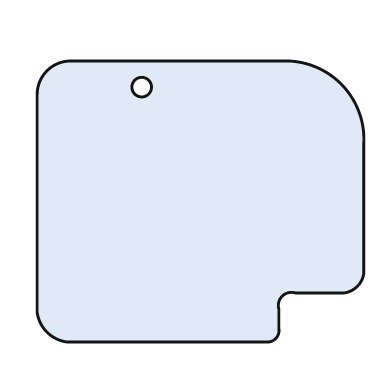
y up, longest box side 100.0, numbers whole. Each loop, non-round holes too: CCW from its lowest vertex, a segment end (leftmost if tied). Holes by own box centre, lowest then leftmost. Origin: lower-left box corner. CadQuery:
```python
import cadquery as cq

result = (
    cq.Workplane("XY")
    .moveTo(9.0, 0.0)
    .lineTo(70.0, 0.0)
    .threePointArc((73.0, 1.0), (74.0, 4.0))
    .lineTo(74.0, 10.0)
    .threePointArc((75.0, 14.0), (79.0, 15.0))
    .lineTo(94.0, 15.0)
    .threePointArc((98.0, 17.0), (100.0, 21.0))
    .lineTo(100.0, 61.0)
    .threePointArc((93.0, 79.0), (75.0, 86.0))
    .lineTo(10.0, 86.0)
    .threePointArc((3.0, 83.0), (0.0, 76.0))
    .lineTo(0.0, 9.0)
    .threePointArc((3.0, 3.0), (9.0, 0.0))
    .close()
    .moveTo(32.0, 78.0)
    .circle(3.0)
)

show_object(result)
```